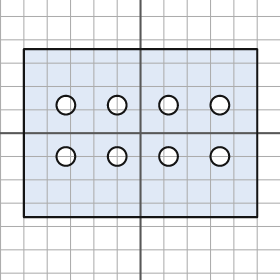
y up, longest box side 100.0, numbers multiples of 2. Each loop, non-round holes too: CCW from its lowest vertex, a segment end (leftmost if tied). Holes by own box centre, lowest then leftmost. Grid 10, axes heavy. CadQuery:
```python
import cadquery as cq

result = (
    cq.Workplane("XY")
    .moveTo(-50.0, -36.0)
    .lineTo(50.0, -36.0)
    .lineTo(50.0, 36.0)
    .lineTo(-50.0, 36.0)
    .close()
    .moveTo(-32.0, -10.0)
    .circle(4.0)
    .moveTo(-10.0, -10.0)
    .circle(4.0)
    .moveTo(12.0, -10.0)
    .circle(4.0)
    .moveTo(34.0, -10.0)
    .circle(4.0)
    .moveTo(-32.0, 12.0)
    .circle(4.0)
    .moveTo(-10.0, 12.0)
    .circle(4.0)
    .moveTo(12.0, 12.0)
    .circle(4.0)
    .moveTo(34.0, 12.0)
    .circle(4.0)
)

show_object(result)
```